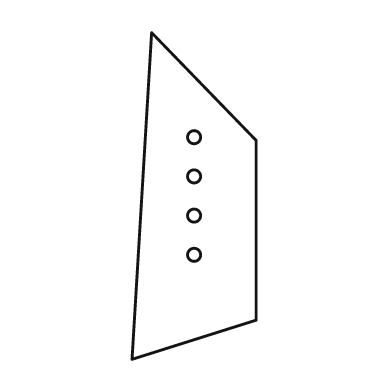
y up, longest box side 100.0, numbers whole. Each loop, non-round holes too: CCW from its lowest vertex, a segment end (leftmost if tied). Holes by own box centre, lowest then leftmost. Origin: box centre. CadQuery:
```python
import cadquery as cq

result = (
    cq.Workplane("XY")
    .moveTo(-19.0, -50.0)
    .lineTo(19.0, -38.0)
    .lineTo(19.0, 17.0)
    .lineTo(-13.0, 50.0)
    .close()
    .moveTo(0.0, -18.0)
    .circle(2.0)
    .moveTo(0.0, -6.0)
    .circle(2.0)
    .moveTo(0.0, 6.0)
    .circle(2.0)
    .moveTo(0.0, 18.0)
    .circle(2.0)
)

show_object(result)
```